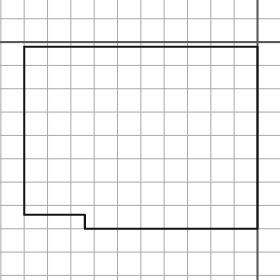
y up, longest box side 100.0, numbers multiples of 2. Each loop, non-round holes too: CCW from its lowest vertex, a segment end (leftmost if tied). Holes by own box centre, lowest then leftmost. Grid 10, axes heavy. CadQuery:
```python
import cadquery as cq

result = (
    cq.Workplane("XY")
    .moveTo(-74.0, -80.0)
    .lineTo(0.0, -80.0)
    .lineTo(0.0, -2.0)
    .lineTo(-100.0, -2.0)
    .lineTo(-100.0, -74.0)
    .lineTo(-74.0, -74.0)
    .close()
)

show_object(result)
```